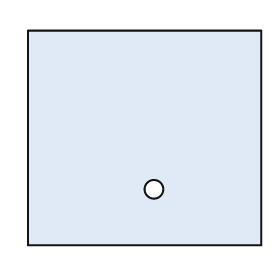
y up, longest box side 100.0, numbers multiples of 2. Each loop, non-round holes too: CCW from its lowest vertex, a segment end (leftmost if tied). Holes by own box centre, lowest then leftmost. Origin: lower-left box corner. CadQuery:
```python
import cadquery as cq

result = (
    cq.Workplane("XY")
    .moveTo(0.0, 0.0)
    .lineTo(100.0, 0.0)
    .lineTo(100.0, 92.0)
    .lineTo(0.0, 92.0)
    .close()
    .moveTo(54.0, 24.0)
    .circle(4.0)
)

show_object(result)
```